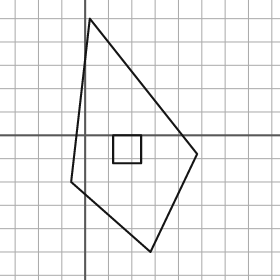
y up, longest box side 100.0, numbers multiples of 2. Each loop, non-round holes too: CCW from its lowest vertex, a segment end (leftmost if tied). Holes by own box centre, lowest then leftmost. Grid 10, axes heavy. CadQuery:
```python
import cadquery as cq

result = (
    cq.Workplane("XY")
    .moveTo(28.0, -50.0)
    .lineTo(48.0, -8.0)
    .lineTo(2.0, 50.0)
    .lineTo(-6.0, -20.0)
    .close()
    .moveTo(12.0, -12.0)
    .lineTo(24.0, -12.0)
    .lineTo(24.0, 0.0)
    .lineTo(12.0, 0.0)
    .close()
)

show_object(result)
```